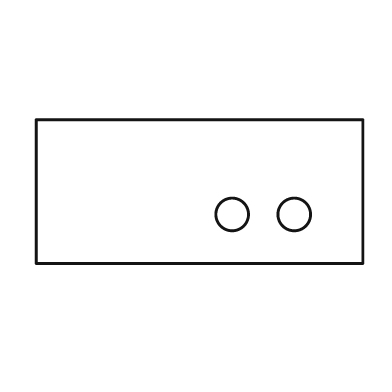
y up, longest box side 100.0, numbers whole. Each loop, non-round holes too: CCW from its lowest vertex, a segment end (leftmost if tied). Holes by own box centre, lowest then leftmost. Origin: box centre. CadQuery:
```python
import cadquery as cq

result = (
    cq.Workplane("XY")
    .moveTo(-50.0, -22.0)
    .lineTo(50.0, -22.0)
    .lineTo(50.0, 22.0)
    .lineTo(-50.0, 22.0)
    .close()
    .moveTo(10.0, -7.0)
    .circle(5.0)
    .moveTo(29.0, -7.0)
    .circle(5.0)
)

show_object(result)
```